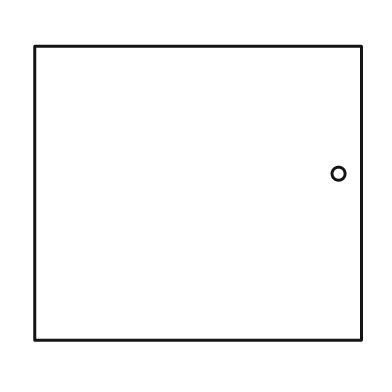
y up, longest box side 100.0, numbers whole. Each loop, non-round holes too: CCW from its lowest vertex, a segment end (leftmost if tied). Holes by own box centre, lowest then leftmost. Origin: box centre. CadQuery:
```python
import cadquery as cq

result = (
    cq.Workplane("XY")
    .moveTo(-50.0, -45.0)
    .lineTo(50.0, -45.0)
    .lineTo(50.0, 45.0)
    .lineTo(-50.0, 45.0)
    .close()
    .moveTo(43.0, 6.0)
    .circle(2.0)
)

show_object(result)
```